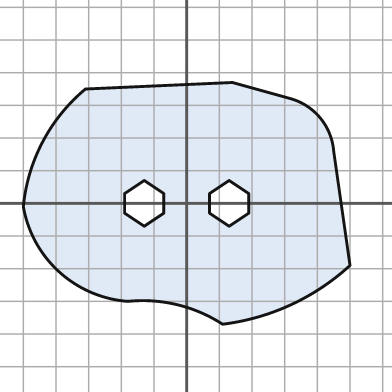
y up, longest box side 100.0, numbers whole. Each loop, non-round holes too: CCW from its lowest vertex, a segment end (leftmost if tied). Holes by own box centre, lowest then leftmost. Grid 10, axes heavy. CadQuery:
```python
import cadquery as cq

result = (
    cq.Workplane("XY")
    .moveTo(11.0, -37.0)
    .threePointArc((32.0, -31.0), (50.0, -19.0))
    .lineTo(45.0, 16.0)
    .threePointArc((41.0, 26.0), (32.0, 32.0))
    .lineTo(14.0, 37.0)
    .lineTo(-31.0, 35.0)
    .threePointArc((-44.0, 19.0), (-50.0, -1.0))
    .threePointArc((-39.0, -21.0), (-18.0, -30.0))
    .threePointArc((-3.0, -31.0), (11.0, -37.0))
    .close()
    .moveTo(-13.0, -7.0)
    .lineTo(-7.0, -3.0)
    .lineTo(-7.0, 3.0)
    .lineTo(-13.0, 7.0)
    .lineTo(-19.0, 3.0)
    .lineTo(-19.0, -3.0)
    .close()
    .moveTo(13.0, -7.0)
    .lineTo(19.0, -3.0)
    .lineTo(19.0, 3.0)
    .lineTo(13.0, 7.0)
    .lineTo(7.0, 3.0)
    .lineTo(7.0, -3.0)
    .close()
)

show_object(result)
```